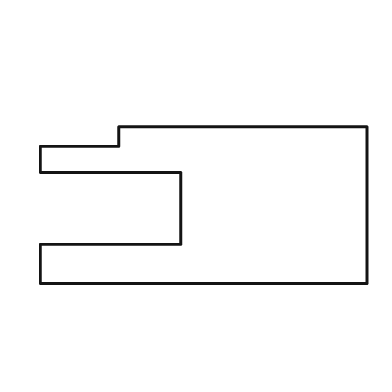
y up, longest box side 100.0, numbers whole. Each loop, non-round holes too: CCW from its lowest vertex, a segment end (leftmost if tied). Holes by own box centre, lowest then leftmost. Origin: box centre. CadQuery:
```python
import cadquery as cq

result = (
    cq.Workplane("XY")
    .moveTo(-50.0, -24.0)
    .lineTo(50.0, -24.0)
    .lineTo(50.0, 24.0)
    .lineTo(-26.0, 24.0)
    .lineTo(-26.0, 18.0)
    .lineTo(-50.0, 18.0)
    .lineTo(-50.0, 10.0)
    .lineTo(-7.0, 10.0)
    .lineTo(-7.0, -12.0)
    .lineTo(-50.0, -12.0)
    .close()
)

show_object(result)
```